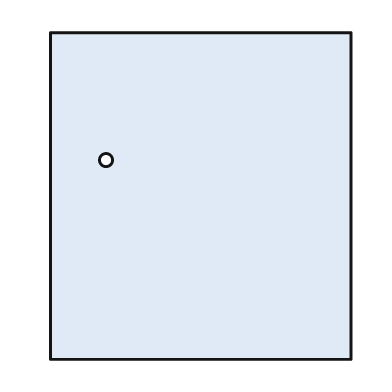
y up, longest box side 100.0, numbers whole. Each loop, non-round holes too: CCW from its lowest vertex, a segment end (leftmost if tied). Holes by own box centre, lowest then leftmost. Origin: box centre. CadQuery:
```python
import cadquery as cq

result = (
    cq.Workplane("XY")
    .moveTo(-46.0, -50.0)
    .lineTo(46.0, -50.0)
    .lineTo(46.0, 50.0)
    .lineTo(-46.0, 50.0)
    .close()
    .moveTo(-29.0, 11.0)
    .circle(2.0)
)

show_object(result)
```